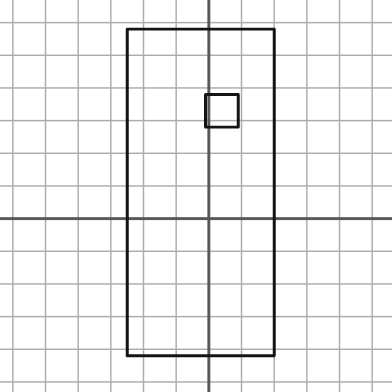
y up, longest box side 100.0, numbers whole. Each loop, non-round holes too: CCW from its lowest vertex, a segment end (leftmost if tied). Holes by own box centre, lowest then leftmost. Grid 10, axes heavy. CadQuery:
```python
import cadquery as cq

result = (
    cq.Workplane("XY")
    .moveTo(-25.0, -42.0)
    .lineTo(20.0, -42.0)
    .lineTo(20.0, 58.0)
    .lineTo(-25.0, 58.0)
    .close()
    .moveTo(-1.0, 28.0)
    .lineTo(9.0, 28.0)
    .lineTo(9.0, 38.0)
    .lineTo(-1.0, 38.0)
    .close()
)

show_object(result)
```